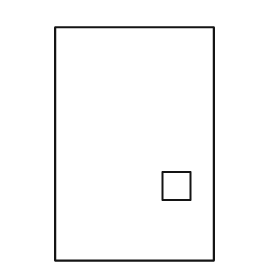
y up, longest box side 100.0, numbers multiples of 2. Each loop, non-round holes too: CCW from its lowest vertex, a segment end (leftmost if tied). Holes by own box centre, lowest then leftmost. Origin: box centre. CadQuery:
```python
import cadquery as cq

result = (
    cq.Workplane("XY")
    .moveTo(-34.0, -50.0)
    .lineTo(34.0, -50.0)
    .lineTo(34.0, 50.0)
    .lineTo(-34.0, 50.0)
    .close()
    .moveTo(12.0, -24.0)
    .lineTo(24.0, -24.0)
    .lineTo(24.0, -12.0)
    .lineTo(12.0, -12.0)
    .close()
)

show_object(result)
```